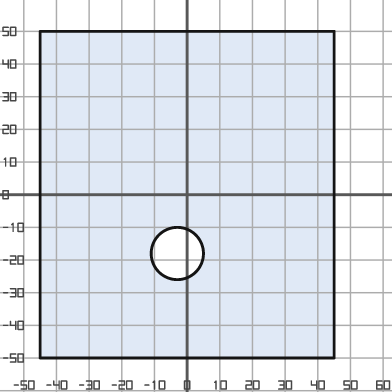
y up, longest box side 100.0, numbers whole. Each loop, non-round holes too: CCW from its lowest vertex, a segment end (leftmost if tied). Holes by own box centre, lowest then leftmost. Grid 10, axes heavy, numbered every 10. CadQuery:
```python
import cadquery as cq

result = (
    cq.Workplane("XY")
    .moveTo(-45.0, -50.0)
    .lineTo(45.0, -50.0)
    .lineTo(45.0, 50.0)
    .lineTo(-45.0, 50.0)
    .close()
    .moveTo(-3.0, -18.0)
    .circle(8.0)
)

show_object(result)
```